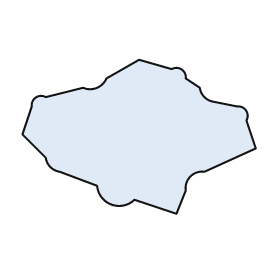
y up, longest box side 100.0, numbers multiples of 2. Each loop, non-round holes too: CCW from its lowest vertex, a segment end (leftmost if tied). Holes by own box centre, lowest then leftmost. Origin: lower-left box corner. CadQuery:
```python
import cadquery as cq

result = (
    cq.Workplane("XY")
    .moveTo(66.0, 0.0)
    .lineTo(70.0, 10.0)
    .threePointArc((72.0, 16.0), (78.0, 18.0))
    .lineTo(100.0, 28.0)
    .lineTo(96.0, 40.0)
    .threePointArc((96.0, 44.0), (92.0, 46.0))
    .lineTo(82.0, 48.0)
    .threePointArc((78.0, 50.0), (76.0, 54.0))
    .lineTo(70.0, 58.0)
    .threePointArc((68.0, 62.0), (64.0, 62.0))
    .lineTo(50.0, 66.0)
    .lineTo(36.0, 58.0)
    .threePointArc((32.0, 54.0), (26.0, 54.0))
    .lineTo(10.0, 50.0)
    .threePointArc((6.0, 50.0), (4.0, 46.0))
    .lineTo(0.0, 34.0)
    .lineTo(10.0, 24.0)
    .threePointArc((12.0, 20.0), (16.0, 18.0))
    .lineTo(32.0, 12.0)
    .threePointArc((38.0, 4.0), (48.0, 6.0))
    .close()
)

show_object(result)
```